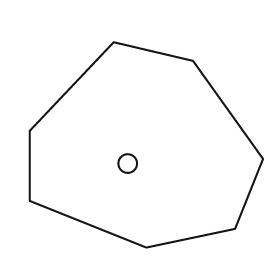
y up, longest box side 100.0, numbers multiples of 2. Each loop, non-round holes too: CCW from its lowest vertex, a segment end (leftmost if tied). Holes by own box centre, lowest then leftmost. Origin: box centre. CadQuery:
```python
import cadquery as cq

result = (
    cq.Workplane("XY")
    .moveTo(0.0, -44.0)
    .lineTo(38.0, -36.0)
    .lineTo(50.0, -6.0)
    .lineTo(20.0, 36.0)
    .lineTo(-14.0, 44.0)
    .lineTo(-50.0, 6.0)
    .lineTo(-50.0, -24.0)
    .close()
    .moveTo(-8.0, -8.0)
    .circle(4.0)
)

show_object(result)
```